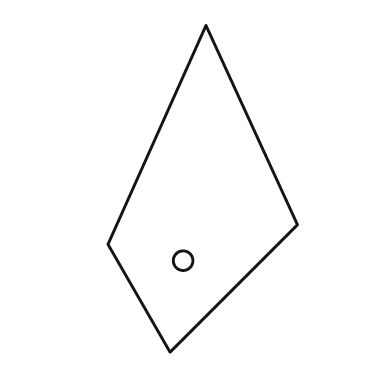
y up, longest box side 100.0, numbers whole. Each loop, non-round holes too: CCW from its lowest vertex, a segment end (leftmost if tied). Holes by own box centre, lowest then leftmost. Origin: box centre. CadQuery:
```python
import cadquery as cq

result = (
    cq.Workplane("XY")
    .moveTo(-10.0, -50.0)
    .lineTo(29.0, -11.0)
    .lineTo(1.0, 50.0)
    .lineTo(-29.0, -17.0)
    .close()
    .moveTo(-6.0, -22.0)
    .circle(3.0)
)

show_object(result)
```